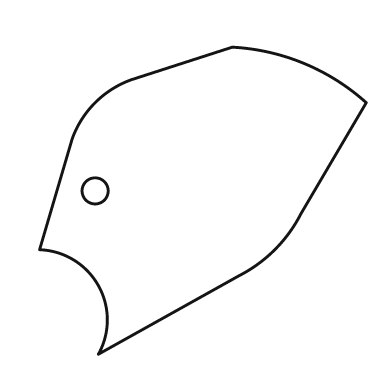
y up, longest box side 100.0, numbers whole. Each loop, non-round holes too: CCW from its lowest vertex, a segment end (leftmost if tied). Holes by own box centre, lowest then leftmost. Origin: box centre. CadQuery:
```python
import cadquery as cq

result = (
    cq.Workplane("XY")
    .moveTo(-32.0, -47.0)
    .lineTo(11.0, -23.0)
    .threePointArc((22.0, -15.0), (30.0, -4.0))
    .lineTo(50.0, 30.0)
    .threePointArc((31.0, 42.0), (9.0, 47.0))
    .lineTo(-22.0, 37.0)
    .threePointArc((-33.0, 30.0), (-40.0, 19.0))
    .lineTo(-50.0, -15.0)
    .threePointArc((-32.0, -26.0), (-32.0, -47.0))
    .close()
    .moveTo(-33.0, 3.0)
    .circle(4.0)
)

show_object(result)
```